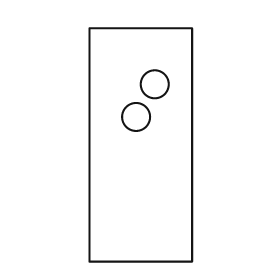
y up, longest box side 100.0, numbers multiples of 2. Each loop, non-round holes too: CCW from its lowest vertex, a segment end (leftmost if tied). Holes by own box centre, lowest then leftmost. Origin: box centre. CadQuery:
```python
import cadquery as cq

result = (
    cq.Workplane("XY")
    .moveTo(-22.0, -50.0)
    .lineTo(22.0, -50.0)
    .lineTo(22.0, 50.0)
    .lineTo(-22.0, 50.0)
    .close()
    .moveTo(-2.0, 12.0)
    .circle(6.0)
    .moveTo(6.0, 26.0)
    .circle(6.0)
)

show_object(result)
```